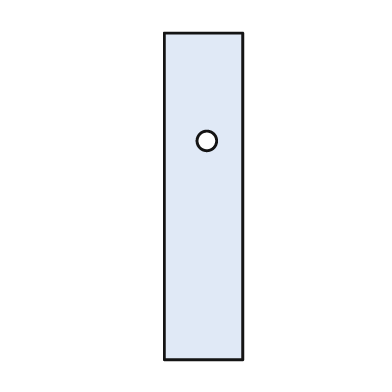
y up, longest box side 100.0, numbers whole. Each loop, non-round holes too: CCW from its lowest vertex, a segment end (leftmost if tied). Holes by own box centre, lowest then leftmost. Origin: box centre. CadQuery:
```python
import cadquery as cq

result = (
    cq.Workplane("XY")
    .moveTo(-12.0, -50.0)
    .lineTo(12.0, -50.0)
    .lineTo(12.0, 50.0)
    .lineTo(-12.0, 50.0)
    .close()
    .moveTo(1.0, 17.0)
    .circle(3.0)
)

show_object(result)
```